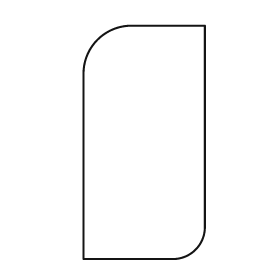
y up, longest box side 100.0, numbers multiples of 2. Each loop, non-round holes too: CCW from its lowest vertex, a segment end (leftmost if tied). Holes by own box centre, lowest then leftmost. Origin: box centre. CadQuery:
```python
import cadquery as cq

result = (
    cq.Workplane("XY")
    .moveTo(-26.0, -50.0)
    .lineTo(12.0, -50.0)
    .threePointArc((22.0, -46.0), (26.0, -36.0))
    .lineTo(26.0, 50.0)
    .lineTo(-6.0, 50.0)
    .threePointArc((-20.0, 44.0), (-26.0, 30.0))
    .close()
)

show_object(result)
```